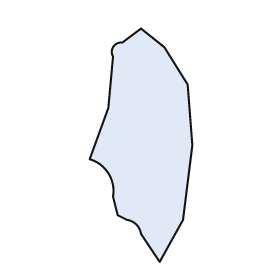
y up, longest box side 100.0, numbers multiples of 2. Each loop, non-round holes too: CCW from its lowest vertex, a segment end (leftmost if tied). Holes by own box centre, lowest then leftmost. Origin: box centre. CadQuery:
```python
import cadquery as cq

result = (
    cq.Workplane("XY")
    .moveTo(8.0, -50.0)
    .lineTo(18.0, -32.0)
    .lineTo(22.0, 0.0)
    .lineTo(20.0, 26.0)
    .lineTo(10.0, 42.0)
    .lineTo(0.0, 50.0)
    .lineTo(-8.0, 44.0)
    .threePointArc((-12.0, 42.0), (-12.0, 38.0))
    .lineTo(-14.0, 16.0)
    .lineTo(-22.0, -6.0)
    .threePointArc((-14.0, -12.0), (-12.0, -22.0))
    .lineTo(-10.0, -30.0)
    .lineTo(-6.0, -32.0)
    .threePointArc((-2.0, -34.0), (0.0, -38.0))
    .close()
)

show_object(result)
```